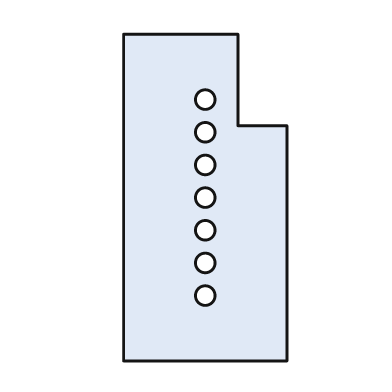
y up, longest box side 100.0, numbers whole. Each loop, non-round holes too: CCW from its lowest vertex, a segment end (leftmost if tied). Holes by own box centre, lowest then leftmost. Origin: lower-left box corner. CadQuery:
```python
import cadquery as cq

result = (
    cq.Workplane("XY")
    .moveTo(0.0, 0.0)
    .lineTo(50.0, 0.0)
    .lineTo(50.0, 72.0)
    .lineTo(35.0, 72.0)
    .lineTo(35.0, 100.0)
    .lineTo(0.0, 100.0)
    .close()
    .moveTo(25.0, 20.0)
    .circle(3.0)
    .moveTo(25.0, 30.0)
    .circle(3.0)
    .moveTo(25.0, 40.0)
    .circle(3.0)
    .moveTo(25.0, 50.0)
    .circle(3.0)
    .moveTo(25.0, 60.0)
    .circle(3.0)
    .moveTo(25.0, 70.0)
    .circle(3.0)
    .moveTo(25.0, 80.0)
    .circle(3.0)
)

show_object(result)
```